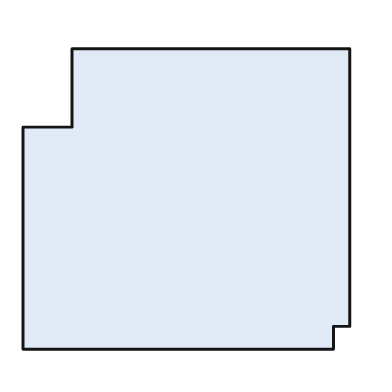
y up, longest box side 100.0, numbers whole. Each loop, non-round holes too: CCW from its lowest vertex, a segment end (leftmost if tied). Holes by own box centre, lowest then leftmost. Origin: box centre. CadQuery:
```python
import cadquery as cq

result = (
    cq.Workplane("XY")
    .moveTo(-50.0, -46.0)
    .lineTo(45.0, -46.0)
    .lineTo(45.0, -39.0)
    .lineTo(50.0, -39.0)
    .lineTo(50.0, 46.0)
    .lineTo(-35.0, 46.0)
    .lineTo(-35.0, 22.0)
    .lineTo(-50.0, 22.0)
    .close()
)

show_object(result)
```